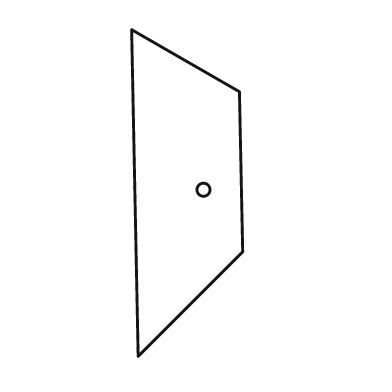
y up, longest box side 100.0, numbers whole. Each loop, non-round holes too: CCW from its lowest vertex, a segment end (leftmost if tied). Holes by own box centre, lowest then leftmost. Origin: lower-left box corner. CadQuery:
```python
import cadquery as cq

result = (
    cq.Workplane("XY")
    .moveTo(2.0, 0.0)
    .lineTo(34.0, 32.0)
    .lineTo(33.0, 81.0)
    .lineTo(0.0, 100.0)
    .close()
    .moveTo(22.0, 51.0)
    .circle(2.0)
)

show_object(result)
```